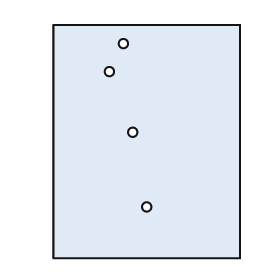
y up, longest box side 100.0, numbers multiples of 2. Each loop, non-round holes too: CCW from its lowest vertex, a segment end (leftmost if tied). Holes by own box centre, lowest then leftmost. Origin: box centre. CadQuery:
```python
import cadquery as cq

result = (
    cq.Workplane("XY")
    .moveTo(-40.0, -50.0)
    .lineTo(40.0, -50.0)
    .lineTo(40.0, 50.0)
    .lineTo(-40.0, 50.0)
    .close()
    .moveTo(0.0, -28.0)
    .circle(2.0)
    .moveTo(-6.0, 4.0)
    .circle(2.0)
    .moveTo(-16.0, 30.0)
    .circle(2.0)
    .moveTo(-10.0, 42.0)
    .circle(2.0)
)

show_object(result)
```